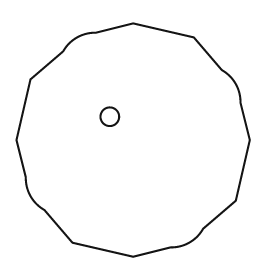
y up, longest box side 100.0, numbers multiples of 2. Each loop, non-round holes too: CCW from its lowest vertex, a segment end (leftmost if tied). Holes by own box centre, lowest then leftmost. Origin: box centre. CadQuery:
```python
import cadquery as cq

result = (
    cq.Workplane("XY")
    .moveTo(0.0, -50.0)
    .lineTo(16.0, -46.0)
    .threePointArc((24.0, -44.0), (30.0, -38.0))
    .lineTo(44.0, -26.0)
    .lineTo(50.0, 0.0)
    .lineTo(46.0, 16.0)
    .threePointArc((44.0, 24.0), (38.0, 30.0))
    .lineTo(26.0, 44.0)
    .lineTo(0.0, 50.0)
    .lineTo(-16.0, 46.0)
    .threePointArc((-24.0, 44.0), (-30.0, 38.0))
    .lineTo(-44.0, 26.0)
    .lineTo(-50.0, 0.0)
    .lineTo(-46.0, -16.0)
    .threePointArc((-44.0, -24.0), (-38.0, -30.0))
    .lineTo(-26.0, -44.0)
    .close()
    .moveTo(-10.0, 10.0)
    .circle(4.0)
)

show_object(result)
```